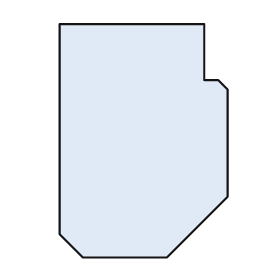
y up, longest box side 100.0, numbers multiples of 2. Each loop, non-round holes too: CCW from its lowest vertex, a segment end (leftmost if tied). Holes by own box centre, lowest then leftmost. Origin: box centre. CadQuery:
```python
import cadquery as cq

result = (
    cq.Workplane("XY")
    .moveTo(-26.0, -50.0)
    .lineTo(10.0, -50.0)
    .lineTo(36.0, -24.0)
    .lineTo(36.0, 22.0)
    .lineTo(32.0, 26.0)
    .lineTo(26.0, 26.0)
    .lineTo(26.0, 50.0)
    .lineTo(-36.0, 50.0)
    .lineTo(-36.0, -40.0)
    .close()
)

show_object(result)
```